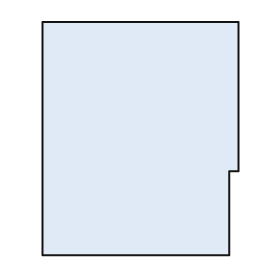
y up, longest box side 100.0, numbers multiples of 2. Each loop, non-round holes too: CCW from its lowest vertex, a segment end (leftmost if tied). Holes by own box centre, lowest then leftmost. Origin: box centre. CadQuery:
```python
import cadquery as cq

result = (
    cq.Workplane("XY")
    .moveTo(-42.0, -50.0)
    .lineTo(38.0, -50.0)
    .lineTo(38.0, -14.0)
    .lineTo(42.0, -14.0)
    .lineTo(42.0, 50.0)
    .lineTo(-42.0, 50.0)
    .close()
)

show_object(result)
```